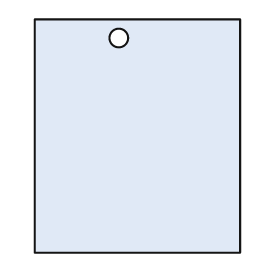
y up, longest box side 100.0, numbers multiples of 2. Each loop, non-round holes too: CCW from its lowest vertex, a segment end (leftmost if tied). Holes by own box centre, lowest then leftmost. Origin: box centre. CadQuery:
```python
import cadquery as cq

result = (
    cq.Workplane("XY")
    .moveTo(-44.0, -50.0)
    .lineTo(44.0, -50.0)
    .lineTo(44.0, 50.0)
    .lineTo(-44.0, 50.0)
    .close()
    .moveTo(-8.0, 42.0)
    .circle(4.0)
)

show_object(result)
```